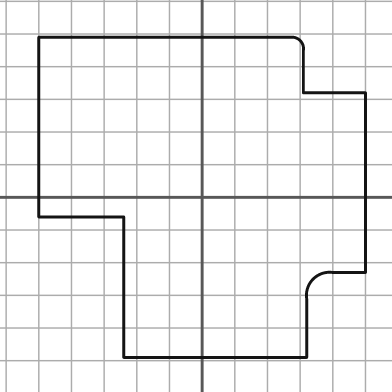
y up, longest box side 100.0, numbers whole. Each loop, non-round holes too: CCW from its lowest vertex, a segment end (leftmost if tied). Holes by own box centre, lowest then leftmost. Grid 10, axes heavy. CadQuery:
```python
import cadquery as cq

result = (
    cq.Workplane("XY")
    .moveTo(-24.0, -49.0)
    .lineTo(32.0, -49.0)
    .lineTo(32.0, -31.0)
    .threePointArc((34.0, -25.0), (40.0, -23.0))
    .lineTo(50.0, -23.0)
    .lineTo(50.0, 32.0)
    .lineTo(31.0, 32.0)
    .lineTo(31.0, 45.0)
    .threePointArc((30.0, 48.0), (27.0, 49.0))
    .lineTo(-50.0, 49.0)
    .lineTo(-50.0, -6.0)
    .lineTo(-24.0, -6.0)
    .close()
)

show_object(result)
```